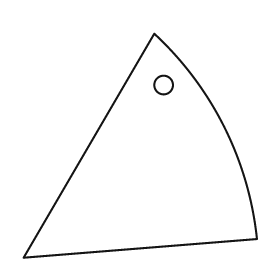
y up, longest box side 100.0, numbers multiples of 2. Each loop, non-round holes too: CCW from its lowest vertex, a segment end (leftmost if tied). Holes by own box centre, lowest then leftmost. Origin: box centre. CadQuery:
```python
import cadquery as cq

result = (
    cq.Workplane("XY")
    .moveTo(-50.0, -48.0)
    .lineTo(50.0, -40.0)
    .threePointArc((36.0, 8.0), (6.0, 48.0))
    .close()
    .moveTo(10.0, 26.0)
    .circle(4.0)
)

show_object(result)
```